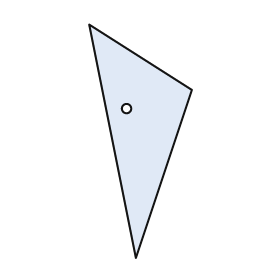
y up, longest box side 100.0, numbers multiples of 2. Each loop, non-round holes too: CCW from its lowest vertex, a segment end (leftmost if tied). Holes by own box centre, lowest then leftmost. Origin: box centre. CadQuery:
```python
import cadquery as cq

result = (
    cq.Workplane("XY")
    .moveTo(-2.0, -50.0)
    .lineTo(22.0, 22.0)
    .lineTo(-22.0, 50.0)
    .close()
    .moveTo(-6.0, 14.0)
    .circle(2.0)
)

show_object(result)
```